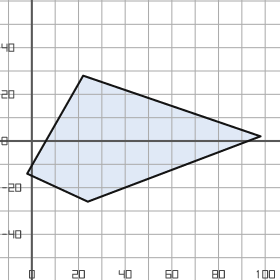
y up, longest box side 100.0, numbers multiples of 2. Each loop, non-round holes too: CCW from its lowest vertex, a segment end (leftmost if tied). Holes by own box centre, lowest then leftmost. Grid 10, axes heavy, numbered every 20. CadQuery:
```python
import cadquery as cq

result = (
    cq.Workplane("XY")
    .moveTo(24.0, -26.0)
    .lineTo(98.0, 2.0)
    .lineTo(22.0, 28.0)
    .lineTo(-2.0, -14.0)
    .close()
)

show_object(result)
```